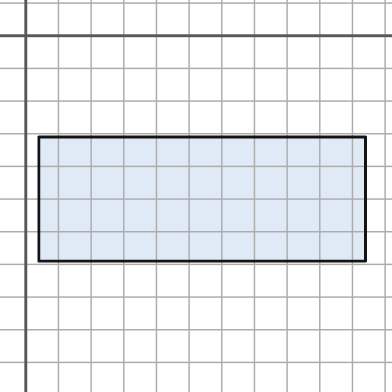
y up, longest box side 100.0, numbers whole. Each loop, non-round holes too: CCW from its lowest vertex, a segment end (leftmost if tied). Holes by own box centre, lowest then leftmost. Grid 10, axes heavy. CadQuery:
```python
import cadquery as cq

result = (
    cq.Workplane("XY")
    .moveTo(4.0, -69.0)
    .lineTo(104.0, -69.0)
    .lineTo(104.0, -31.0)
    .lineTo(4.0, -31.0)
    .close()
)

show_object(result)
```